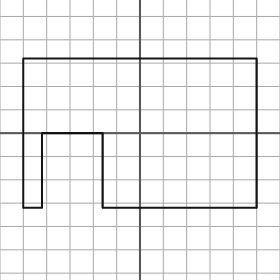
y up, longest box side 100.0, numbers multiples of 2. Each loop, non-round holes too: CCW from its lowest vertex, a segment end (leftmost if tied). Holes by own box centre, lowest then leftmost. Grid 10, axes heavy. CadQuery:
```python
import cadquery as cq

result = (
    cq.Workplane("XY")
    .moveTo(-50.0, -32.0)
    .lineTo(-42.0, -32.0)
    .lineTo(-42.0, 0.0)
    .lineTo(-16.0, 0.0)
    .lineTo(-16.0, -32.0)
    .lineTo(50.0, -32.0)
    .lineTo(50.0, 32.0)
    .lineTo(-50.0, 32.0)
    .close()
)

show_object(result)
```